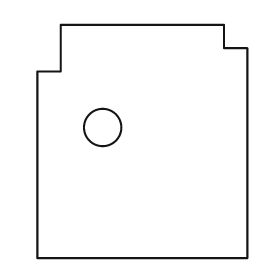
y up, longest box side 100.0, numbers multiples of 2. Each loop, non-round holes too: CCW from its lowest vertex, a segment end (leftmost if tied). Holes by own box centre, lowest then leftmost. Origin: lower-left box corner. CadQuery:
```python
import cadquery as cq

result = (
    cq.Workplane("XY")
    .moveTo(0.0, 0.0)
    .lineTo(90.0, 0.0)
    .lineTo(90.0, 90.0)
    .lineTo(80.0, 90.0)
    .lineTo(80.0, 100.0)
    .lineTo(10.0, 100.0)
    .lineTo(10.0, 80.0)
    .lineTo(0.0, 80.0)
    .close()
    .moveTo(28.0, 56.0)
    .circle(8.0)
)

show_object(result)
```